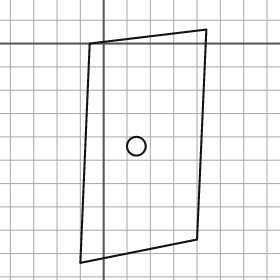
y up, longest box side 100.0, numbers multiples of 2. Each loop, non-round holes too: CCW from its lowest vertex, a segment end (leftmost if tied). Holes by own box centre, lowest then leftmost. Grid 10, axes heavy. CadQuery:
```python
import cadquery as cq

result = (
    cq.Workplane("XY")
    .moveTo(-10.0, -94.0)
    .lineTo(40.0, -84.0)
    .lineTo(44.0, 6.0)
    .lineTo(-6.0, 0.0)
    .close()
    .moveTo(14.0, -44.0)
    .circle(4.0)
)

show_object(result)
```